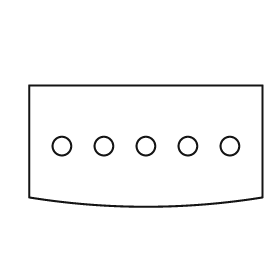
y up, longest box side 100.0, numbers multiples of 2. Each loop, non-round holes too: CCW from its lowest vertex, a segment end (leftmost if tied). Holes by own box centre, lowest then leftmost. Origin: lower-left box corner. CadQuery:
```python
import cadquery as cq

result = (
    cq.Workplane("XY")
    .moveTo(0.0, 4.0)
    .threePointArc((50.0, 0.0), (100.0, 4.0))
    .lineTo(100.0, 52.0)
    .lineTo(0.0, 52.0)
    .close()
    .moveTo(14.0, 26.0)
    .circle(4.0)
    .moveTo(32.0, 26.0)
    .circle(4.0)
    .moveTo(50.0, 26.0)
    .circle(4.0)
    .moveTo(68.0, 26.0)
    .circle(4.0)
    .moveTo(86.0, 26.0)
    .circle(4.0)
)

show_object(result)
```